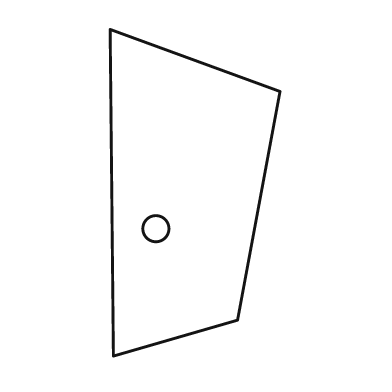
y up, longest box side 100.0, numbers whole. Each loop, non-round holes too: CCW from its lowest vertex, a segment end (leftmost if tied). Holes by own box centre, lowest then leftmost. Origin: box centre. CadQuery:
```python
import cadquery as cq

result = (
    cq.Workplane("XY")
    .moveTo(-25.0, -50.0)
    .lineTo(13.0, -39.0)
    .lineTo(26.0, 31.0)
    .lineTo(-26.0, 50.0)
    .close()
    .moveTo(-12.0, -11.0)
    .circle(4.0)
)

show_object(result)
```